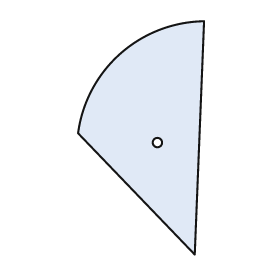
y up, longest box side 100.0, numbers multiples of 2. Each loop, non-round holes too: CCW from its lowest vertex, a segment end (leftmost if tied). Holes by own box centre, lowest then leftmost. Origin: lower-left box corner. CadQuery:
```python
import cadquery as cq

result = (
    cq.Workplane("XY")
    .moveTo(50.0, 0.0)
    .lineTo(54.0, 100.0)
    .threePointArc((18.0, 86.0), (0.0, 52.0))
    .close()
    .moveTo(34.0, 48.0)
    .circle(2.0)
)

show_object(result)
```